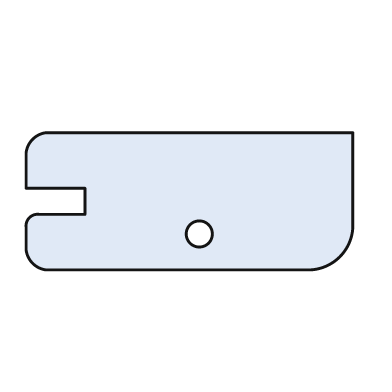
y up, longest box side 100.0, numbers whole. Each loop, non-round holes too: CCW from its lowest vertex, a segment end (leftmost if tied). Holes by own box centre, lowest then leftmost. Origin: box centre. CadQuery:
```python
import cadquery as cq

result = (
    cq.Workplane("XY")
    .moveTo(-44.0, -21.0)
    .lineTo(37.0, -21.0)
    .threePointArc((46.0, -17.0), (50.0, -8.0))
    .lineTo(50.0, 21.0)
    .lineTo(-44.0, 21.0)
    .threePointArc((-48.0, 19.0), (-50.0, 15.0))
    .lineTo(-50.0, 4.0)
    .lineTo(-32.0, 4.0)
    .lineTo(-32.0, -4.0)
    .lineTo(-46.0, -4.0)
    .threePointArc((-49.0, -5.0), (-50.0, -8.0))
    .lineTo(-50.0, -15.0)
    .threePointArc((-48.0, -19.0), (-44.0, -21.0))
    .close()
    .moveTo(3.0, -10.0)
    .circle(4.0)
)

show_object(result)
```